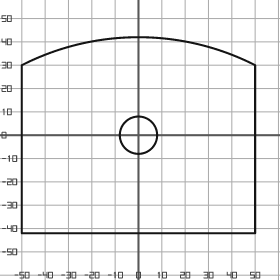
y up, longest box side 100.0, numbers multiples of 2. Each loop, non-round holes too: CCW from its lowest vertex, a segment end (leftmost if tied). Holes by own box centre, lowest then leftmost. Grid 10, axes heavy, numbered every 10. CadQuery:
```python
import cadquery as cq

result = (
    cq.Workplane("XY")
    .moveTo(-50.0, -42.0)
    .lineTo(50.0, -42.0)
    .lineTo(50.0, 30.0)
    .threePointArc((0.0, 42.0), (-50.0, 30.0))
    .close()
    .moveTo(0.0, 0.0)
    .circle(8.0)
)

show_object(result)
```